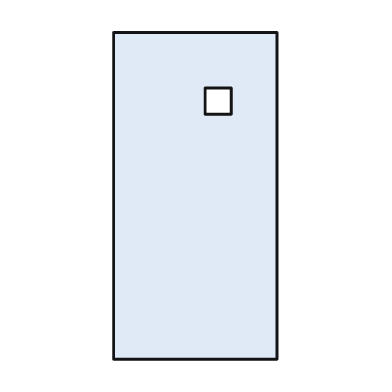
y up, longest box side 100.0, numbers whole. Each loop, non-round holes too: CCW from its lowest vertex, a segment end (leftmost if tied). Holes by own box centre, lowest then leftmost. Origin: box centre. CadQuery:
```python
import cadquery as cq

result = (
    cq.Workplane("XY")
    .moveTo(-25.0, -50.0)
    .lineTo(25.0, -50.0)
    .lineTo(25.0, 50.0)
    .lineTo(-25.0, 50.0)
    .close()
    .moveTo(3.0, 25.0)
    .lineTo(11.0, 25.0)
    .lineTo(11.0, 33.0)
    .lineTo(3.0, 33.0)
    .close()
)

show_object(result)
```